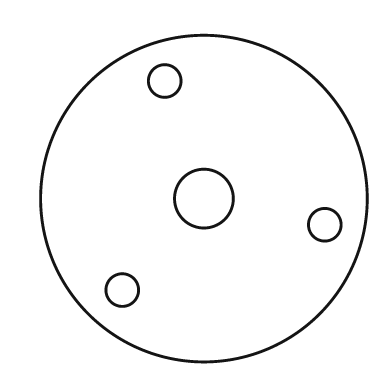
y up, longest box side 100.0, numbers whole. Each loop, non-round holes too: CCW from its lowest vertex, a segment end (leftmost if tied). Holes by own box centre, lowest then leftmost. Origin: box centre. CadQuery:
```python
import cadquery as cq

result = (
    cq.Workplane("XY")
    .moveTo(0.0, 0.0)
    .circle(50.0)
    .moveTo(-25.0, -28.0)
    .circle(5.0)
    .moveTo(37.0, -8.0)
    .circle(5.0)
    .moveTo(0.0, 0.0)
    .circle(9.0)
    .moveTo(-12.0, 36.0)
    .circle(5.0)
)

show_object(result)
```